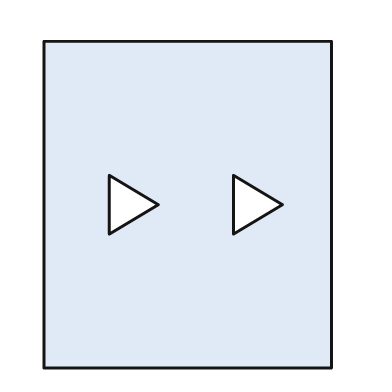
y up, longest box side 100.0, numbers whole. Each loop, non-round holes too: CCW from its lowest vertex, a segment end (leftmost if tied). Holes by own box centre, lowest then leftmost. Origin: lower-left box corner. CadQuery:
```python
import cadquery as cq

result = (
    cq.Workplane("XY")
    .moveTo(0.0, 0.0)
    .lineTo(88.0, 0.0)
    .lineTo(88.0, 100.0)
    .lineTo(0.0, 100.0)
    .close()
    .moveTo(20.0, 41.0)
    .lineTo(35.0, 50.0)
    .lineTo(20.0, 59.0)
    .close()
    .moveTo(58.0, 41.0)
    .lineTo(73.0, 50.0)
    .lineTo(58.0, 59.0)
    .close()
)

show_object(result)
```